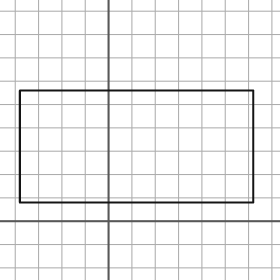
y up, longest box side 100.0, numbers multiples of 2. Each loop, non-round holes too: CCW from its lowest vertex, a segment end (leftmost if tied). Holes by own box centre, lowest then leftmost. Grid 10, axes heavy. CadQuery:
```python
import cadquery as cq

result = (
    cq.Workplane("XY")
    .moveTo(-38.0, 8.0)
    .lineTo(62.0, 8.0)
    .lineTo(62.0, 56.0)
    .lineTo(-38.0, 56.0)
    .close()
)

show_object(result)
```